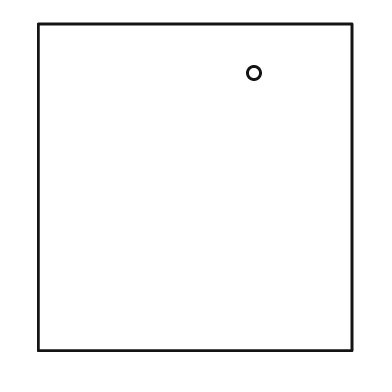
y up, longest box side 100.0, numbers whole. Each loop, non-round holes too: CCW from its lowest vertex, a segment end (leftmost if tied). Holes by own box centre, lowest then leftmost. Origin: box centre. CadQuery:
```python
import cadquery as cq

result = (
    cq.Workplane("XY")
    .moveTo(-48.0, -50.0)
    .lineTo(48.0, -50.0)
    .lineTo(48.0, 50.0)
    .lineTo(-48.0, 50.0)
    .close()
    .moveTo(18.0, 35.0)
    .circle(2.0)
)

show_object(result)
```